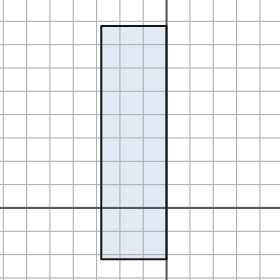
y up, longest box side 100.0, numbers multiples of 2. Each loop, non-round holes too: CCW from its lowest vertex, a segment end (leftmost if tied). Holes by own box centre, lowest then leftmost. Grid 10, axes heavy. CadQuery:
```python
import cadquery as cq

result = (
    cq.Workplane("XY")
    .moveTo(-28.0, -22.0)
    .lineTo(0.0, -22.0)
    .lineTo(0.0, 78.0)
    .lineTo(-28.0, 78.0)
    .close()
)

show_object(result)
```